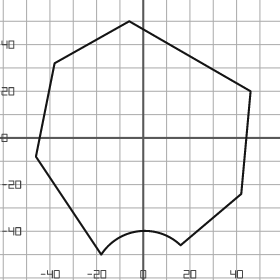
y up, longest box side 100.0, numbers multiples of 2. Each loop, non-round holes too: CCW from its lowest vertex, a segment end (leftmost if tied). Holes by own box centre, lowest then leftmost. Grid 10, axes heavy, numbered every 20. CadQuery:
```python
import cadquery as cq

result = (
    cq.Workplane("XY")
    .moveTo(-18.0, -50.0)
    .threePointArc((-2.0, -40.0), (16.0, -46.0))
    .lineTo(42.0, -24.0)
    .lineTo(46.0, 20.0)
    .lineTo(-6.0, 50.0)
    .lineTo(-38.0, 32.0)
    .lineTo(-46.0, -8.0)
    .close()
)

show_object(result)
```